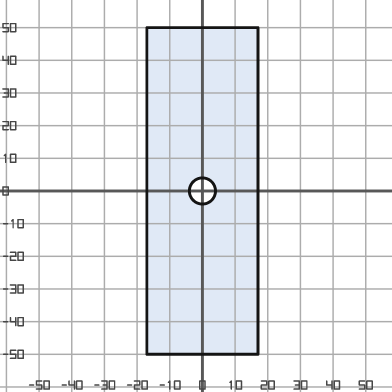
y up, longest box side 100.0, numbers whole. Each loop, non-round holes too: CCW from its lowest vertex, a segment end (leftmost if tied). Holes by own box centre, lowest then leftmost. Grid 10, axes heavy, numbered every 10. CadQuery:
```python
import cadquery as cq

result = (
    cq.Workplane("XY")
    .moveTo(-17.0, -50.0)
    .lineTo(17.0, -50.0)
    .lineTo(17.0, 50.0)
    .lineTo(-17.0, 50.0)
    .close()
    .moveTo(0.0, 0.0)
    .circle(4.0)
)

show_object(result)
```